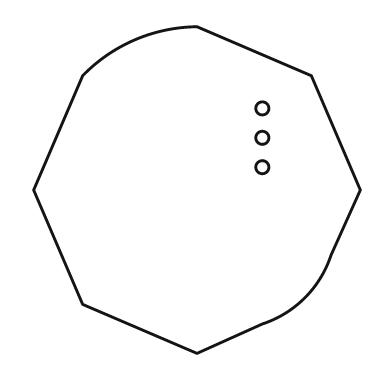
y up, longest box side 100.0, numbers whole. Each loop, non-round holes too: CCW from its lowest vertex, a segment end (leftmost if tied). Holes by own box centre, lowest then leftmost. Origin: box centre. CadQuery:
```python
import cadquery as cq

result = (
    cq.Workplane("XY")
    .moveTo(0.0, -50.0)
    .lineTo(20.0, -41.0)
    .threePointArc((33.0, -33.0), (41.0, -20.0))
    .lineTo(50.0, 0.0)
    .lineTo(35.0, 35.0)
    .lineTo(0.0, 50.0)
    .threePointArc((-19.0, 46.0), (-35.0, 35.0))
    .lineTo(-50.0, 0.0)
    .lineTo(-35.0, -35.0)
    .close()
    .moveTo(20.0, 7.0)
    .circle(2.0)
    .moveTo(20.0, 16.0)
    .circle(2.0)
    .moveTo(20.0, 25.0)
    .circle(2.0)
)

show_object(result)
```